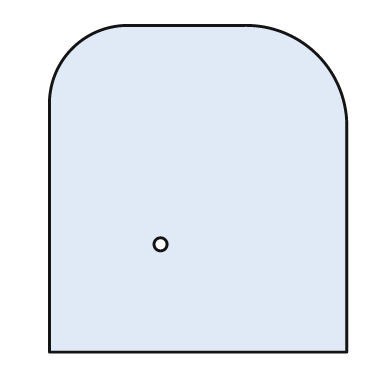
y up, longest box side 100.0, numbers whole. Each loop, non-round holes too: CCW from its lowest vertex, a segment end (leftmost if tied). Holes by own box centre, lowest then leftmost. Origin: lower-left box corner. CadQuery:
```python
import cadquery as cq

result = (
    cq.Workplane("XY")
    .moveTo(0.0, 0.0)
    .lineTo(91.0, 0.0)
    .lineTo(91.0, 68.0)
    .threePointArc((82.0, 91.0), (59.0, 100.0))
    .lineTo(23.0, 100.0)
    .threePointArc((7.0, 93.0), (0.0, 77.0))
    .close()
    .moveTo(34.0, 33.0)
    .circle(2.0)
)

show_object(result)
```